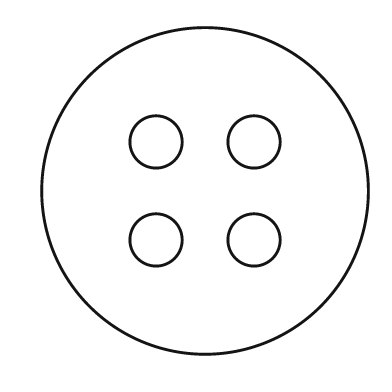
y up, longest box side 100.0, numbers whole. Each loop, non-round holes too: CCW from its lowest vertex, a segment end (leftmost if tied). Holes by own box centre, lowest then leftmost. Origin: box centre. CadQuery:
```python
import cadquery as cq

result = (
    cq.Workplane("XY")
    .moveTo(0.0, 0.0)
    .circle(50.0)
    .moveTo(-15.0, -15.0)
    .circle(8.0)
    .moveTo(15.0, -15.0)
    .circle(8.0)
    .moveTo(-15.0, 15.0)
    .circle(8.0)
    .moveTo(15.0, 15.0)
    .circle(8.0)
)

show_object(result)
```